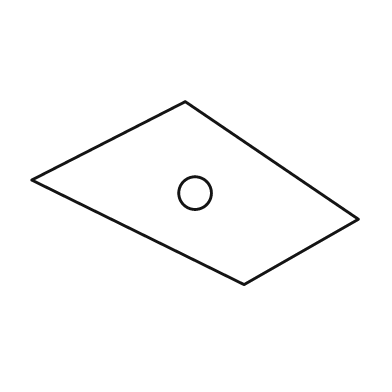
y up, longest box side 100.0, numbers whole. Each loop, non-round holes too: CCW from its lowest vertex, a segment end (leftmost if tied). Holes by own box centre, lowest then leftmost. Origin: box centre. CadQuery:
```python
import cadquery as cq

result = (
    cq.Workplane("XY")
    .moveTo(15.0, -28.0)
    .lineTo(50.0, -8.0)
    .lineTo(-3.0, 28.0)
    .lineTo(-50.0, 4.0)
    .close()
    .moveTo(0.0, 0.0)
    .circle(5.0)
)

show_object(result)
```